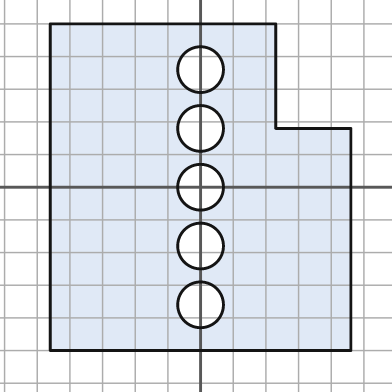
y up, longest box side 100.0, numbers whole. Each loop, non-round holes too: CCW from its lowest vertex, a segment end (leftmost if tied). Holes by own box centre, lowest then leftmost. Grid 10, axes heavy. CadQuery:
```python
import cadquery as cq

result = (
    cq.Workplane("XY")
    .moveTo(-46.0, -50.0)
    .lineTo(46.0, -50.0)
    .lineTo(46.0, 18.0)
    .lineTo(23.0, 18.0)
    .lineTo(23.0, 50.0)
    .lineTo(-46.0, 50.0)
    .close()
    .moveTo(0.0, -36.0)
    .circle(7.0)
    .moveTo(0.0, -18.0)
    .circle(7.0)
    .moveTo(0.0, 0.0)
    .circle(7.0)
    .moveTo(0.0, 18.0)
    .circle(7.0)
    .moveTo(0.0, 36.0)
    .circle(7.0)
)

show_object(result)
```